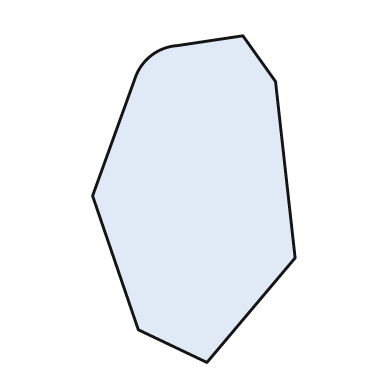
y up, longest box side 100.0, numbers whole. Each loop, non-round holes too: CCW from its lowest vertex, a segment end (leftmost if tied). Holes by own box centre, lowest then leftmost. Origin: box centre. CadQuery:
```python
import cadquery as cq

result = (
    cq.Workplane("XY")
    .moveTo(4.0, -50.0)
    .lineTo(31.0, -18.0)
    .lineTo(25.0, 36.0)
    .lineTo(15.0, 50.0)
    .lineTo(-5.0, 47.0)
    .threePointArc((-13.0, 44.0), (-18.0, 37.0))
    .lineTo(-31.0, 1.0)
    .lineTo(-17.0, -40.0)
    .close()
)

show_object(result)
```